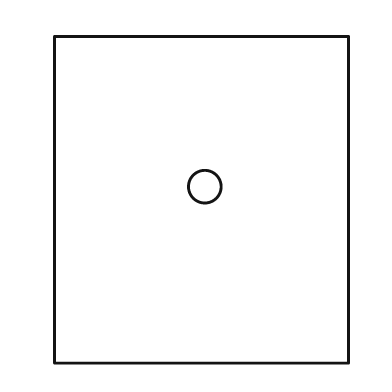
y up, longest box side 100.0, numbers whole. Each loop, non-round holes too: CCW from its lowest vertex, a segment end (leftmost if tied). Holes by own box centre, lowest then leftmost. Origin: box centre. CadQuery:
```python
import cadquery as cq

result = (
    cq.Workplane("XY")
    .moveTo(-45.0, -50.0)
    .lineTo(45.0, -50.0)
    .lineTo(45.0, 50.0)
    .lineTo(-45.0, 50.0)
    .close()
    .moveTo(1.0, 4.0)
    .circle(5.0)
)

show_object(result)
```